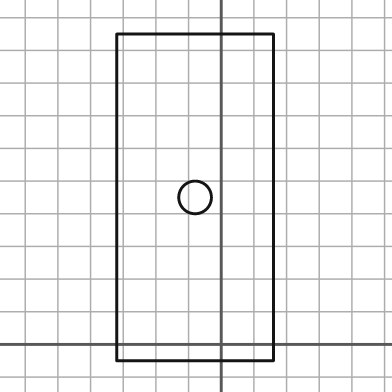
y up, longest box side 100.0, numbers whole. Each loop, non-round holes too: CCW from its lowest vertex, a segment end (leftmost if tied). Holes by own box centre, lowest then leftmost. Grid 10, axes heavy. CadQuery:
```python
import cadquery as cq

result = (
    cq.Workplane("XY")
    .moveTo(-32.0, -5.0)
    .lineTo(16.0, -5.0)
    .lineTo(16.0, 95.0)
    .lineTo(-32.0, 95.0)
    .close()
    .moveTo(-8.0, 45.0)
    .circle(5.0)
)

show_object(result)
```